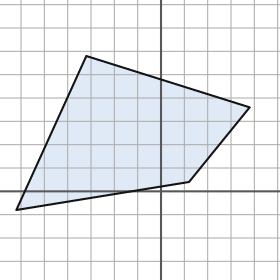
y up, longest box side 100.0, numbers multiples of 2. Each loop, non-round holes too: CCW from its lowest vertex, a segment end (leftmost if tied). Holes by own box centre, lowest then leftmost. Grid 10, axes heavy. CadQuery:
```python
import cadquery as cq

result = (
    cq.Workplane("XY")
    .moveTo(-62.0, -8.0)
    .lineTo(12.0, 4.0)
    .lineTo(38.0, 36.0)
    .lineTo(-32.0, 58.0)
    .close()
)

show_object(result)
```